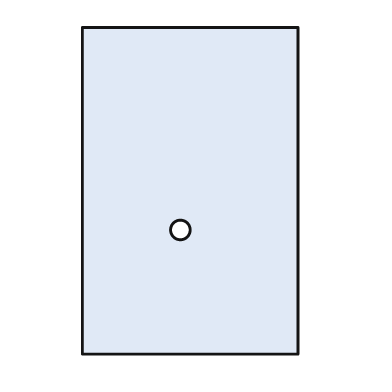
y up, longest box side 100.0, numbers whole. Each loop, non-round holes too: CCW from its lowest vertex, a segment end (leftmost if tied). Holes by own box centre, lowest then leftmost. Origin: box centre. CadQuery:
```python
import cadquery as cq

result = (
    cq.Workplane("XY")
    .moveTo(-33.0, -50.0)
    .lineTo(33.0, -50.0)
    .lineTo(33.0, 50.0)
    .lineTo(-33.0, 50.0)
    .close()
    .moveTo(-3.0, -12.0)
    .circle(3.0)
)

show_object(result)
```